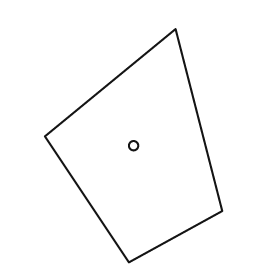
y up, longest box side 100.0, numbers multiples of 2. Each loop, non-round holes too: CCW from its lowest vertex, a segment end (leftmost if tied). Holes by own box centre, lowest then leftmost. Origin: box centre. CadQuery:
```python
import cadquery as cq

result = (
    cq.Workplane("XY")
    .moveTo(-2.0, -50.0)
    .lineTo(38.0, -28.0)
    .lineTo(18.0, 50.0)
    .lineTo(-38.0, 4.0)
    .close()
    .moveTo(0.0, 0.0)
    .circle(2.0)
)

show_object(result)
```